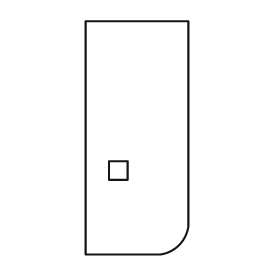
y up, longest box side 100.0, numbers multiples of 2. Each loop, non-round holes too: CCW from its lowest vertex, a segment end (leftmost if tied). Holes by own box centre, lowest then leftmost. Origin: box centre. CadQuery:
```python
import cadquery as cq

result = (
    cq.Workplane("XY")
    .moveTo(-22.0, -50.0)
    .lineTo(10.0, -50.0)
    .threePointArc((18.0, -46.0), (22.0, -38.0))
    .lineTo(22.0, 50.0)
    .lineTo(-22.0, 50.0)
    .close()
    .moveTo(-12.0, -18.0)
    .lineTo(-4.0, -18.0)
    .lineTo(-4.0, -10.0)
    .lineTo(-12.0, -10.0)
    .close()
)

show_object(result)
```